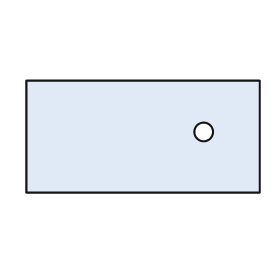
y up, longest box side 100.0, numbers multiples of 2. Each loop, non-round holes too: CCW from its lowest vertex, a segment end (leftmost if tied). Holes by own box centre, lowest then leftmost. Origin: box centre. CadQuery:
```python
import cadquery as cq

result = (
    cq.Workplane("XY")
    .moveTo(-50.0, -24.0)
    .lineTo(50.0, -24.0)
    .lineTo(50.0, 24.0)
    .lineTo(-50.0, 24.0)
    .close()
    .moveTo(26.0, 2.0)
    .circle(4.0)
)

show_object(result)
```